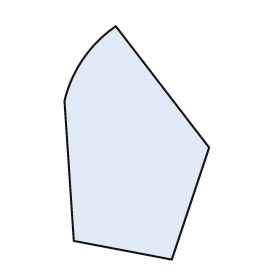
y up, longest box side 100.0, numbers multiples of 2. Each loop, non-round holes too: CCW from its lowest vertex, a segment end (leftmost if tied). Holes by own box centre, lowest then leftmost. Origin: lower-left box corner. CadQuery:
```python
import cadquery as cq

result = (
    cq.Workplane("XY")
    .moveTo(46.0, 0.0)
    .lineTo(62.0, 48.0)
    .lineTo(22.0, 100.0)
    .threePointArc((8.0, 86.0), (0.0, 68.0))
    .lineTo(4.0, 8.0)
    .close()
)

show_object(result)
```